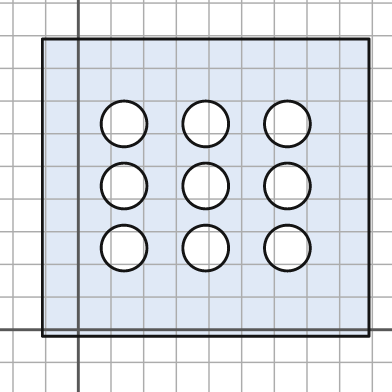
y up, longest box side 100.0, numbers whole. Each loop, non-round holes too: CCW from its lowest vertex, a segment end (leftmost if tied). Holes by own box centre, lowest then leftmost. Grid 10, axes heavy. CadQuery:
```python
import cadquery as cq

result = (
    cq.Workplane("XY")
    .moveTo(-11.0, -2.0)
    .lineTo(89.0, -2.0)
    .lineTo(89.0, 89.0)
    .lineTo(-11.0, 89.0)
    .close()
    .moveTo(14.0, 25.0)
    .circle(7.0)
    .moveTo(39.0, 25.0)
    .circle(7.0)
    .moveTo(64.0, 25.0)
    .circle(7.0)
    .moveTo(14.0, 44.0)
    .circle(7.0)
    .moveTo(39.0, 44.0)
    .circle(7.0)
    .moveTo(64.0, 44.0)
    .circle(7.0)
    .moveTo(14.0, 63.0)
    .circle(7.0)
    .moveTo(39.0, 63.0)
    .circle(7.0)
    .moveTo(64.0, 63.0)
    .circle(7.0)
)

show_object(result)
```